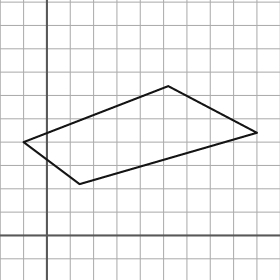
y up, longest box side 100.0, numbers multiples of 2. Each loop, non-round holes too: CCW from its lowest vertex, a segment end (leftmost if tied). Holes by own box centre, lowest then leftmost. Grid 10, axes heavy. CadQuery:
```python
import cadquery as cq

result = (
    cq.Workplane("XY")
    .moveTo(14.0, 22.0)
    .lineTo(90.0, 44.0)
    .lineTo(52.0, 64.0)
    .lineTo(-10.0, 40.0)
    .close()
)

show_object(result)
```